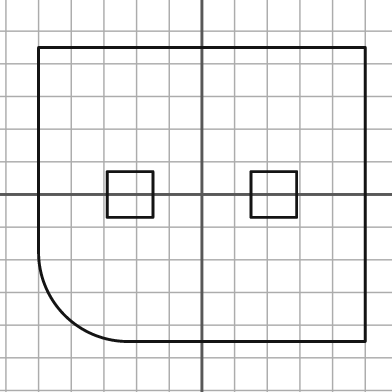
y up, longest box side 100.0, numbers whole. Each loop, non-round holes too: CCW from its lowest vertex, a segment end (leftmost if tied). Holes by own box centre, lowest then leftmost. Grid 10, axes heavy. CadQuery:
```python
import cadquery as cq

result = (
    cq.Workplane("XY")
    .moveTo(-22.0, -45.0)
    .lineTo(50.0, -45.0)
    .lineTo(50.0, 45.0)
    .lineTo(-50.0, 45.0)
    .lineTo(-50.0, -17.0)
    .threePointArc((-42.0, -37.0), (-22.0, -45.0))
    .close()
    .moveTo(-29.0, -7.0)
    .lineTo(-15.0, -7.0)
    .lineTo(-15.0, 7.0)
    .lineTo(-29.0, 7.0)
    .close()
    .moveTo(15.0, -7.0)
    .lineTo(29.0, -7.0)
    .lineTo(29.0, 7.0)
    .lineTo(15.0, 7.0)
    .close()
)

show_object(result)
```